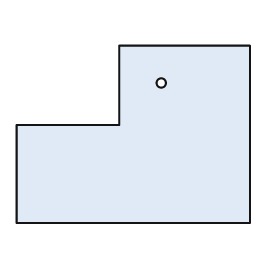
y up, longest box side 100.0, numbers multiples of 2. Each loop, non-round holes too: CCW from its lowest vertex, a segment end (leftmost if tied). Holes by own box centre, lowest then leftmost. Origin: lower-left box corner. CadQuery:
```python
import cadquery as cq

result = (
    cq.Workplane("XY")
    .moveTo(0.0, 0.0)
    .lineTo(100.0, 0.0)
    .lineTo(100.0, 76.0)
    .lineTo(44.0, 76.0)
    .lineTo(44.0, 42.0)
    .lineTo(0.0, 42.0)
    .close()
    .moveTo(62.0, 60.0)
    .circle(2.0)
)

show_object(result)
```